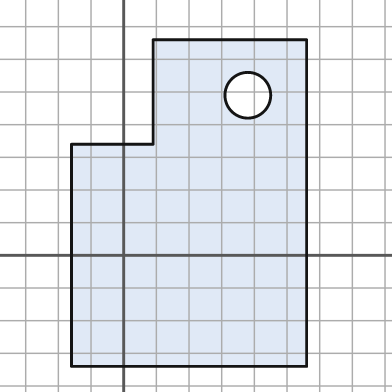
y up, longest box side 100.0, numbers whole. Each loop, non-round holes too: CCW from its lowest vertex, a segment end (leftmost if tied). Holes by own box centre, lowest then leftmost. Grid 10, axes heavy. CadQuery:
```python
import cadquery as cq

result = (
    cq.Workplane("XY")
    .moveTo(-16.0, -34.0)
    .lineTo(56.0, -34.0)
    .lineTo(56.0, 66.0)
    .lineTo(9.0, 66.0)
    .lineTo(9.0, 34.0)
    .lineTo(-16.0, 34.0)
    .close()
    .moveTo(38.0, 49.0)
    .circle(7.0)
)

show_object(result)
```